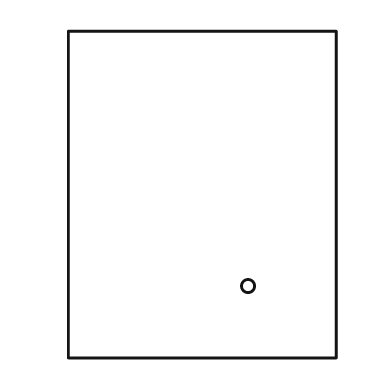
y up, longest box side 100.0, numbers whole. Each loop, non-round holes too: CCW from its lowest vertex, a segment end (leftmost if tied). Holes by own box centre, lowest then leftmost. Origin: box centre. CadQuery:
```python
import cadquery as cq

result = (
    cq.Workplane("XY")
    .moveTo(-41.0, -50.0)
    .lineTo(41.0, -50.0)
    .lineTo(41.0, 50.0)
    .lineTo(-41.0, 50.0)
    .close()
    .moveTo(14.0, -28.0)
    .circle(2.0)
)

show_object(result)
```